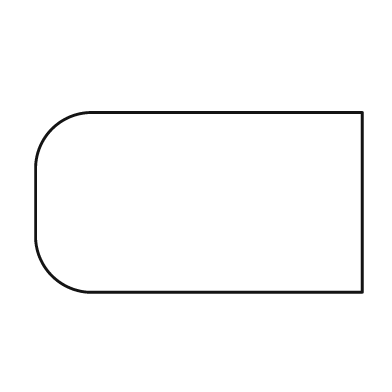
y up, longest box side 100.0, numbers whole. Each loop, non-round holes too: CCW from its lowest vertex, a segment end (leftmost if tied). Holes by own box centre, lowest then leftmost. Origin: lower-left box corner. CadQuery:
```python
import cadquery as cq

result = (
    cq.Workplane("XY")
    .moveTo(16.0, 0.0)
    .lineTo(100.0, 0.0)
    .lineTo(100.0, 55.0)
    .lineTo(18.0, 55.0)
    .threePointArc((5.0, 50.0), (0.0, 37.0))
    .lineTo(0.0, 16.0)
    .threePointArc((5.0, 5.0), (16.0, 0.0))
    .close()
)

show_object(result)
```